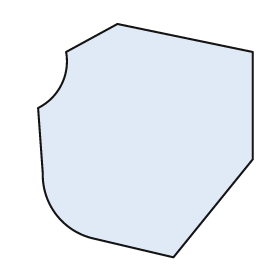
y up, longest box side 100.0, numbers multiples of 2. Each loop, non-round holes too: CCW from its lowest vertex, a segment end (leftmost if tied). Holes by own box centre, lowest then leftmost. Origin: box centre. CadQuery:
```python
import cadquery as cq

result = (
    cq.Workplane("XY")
    .moveTo(12.0, -50.0)
    .lineTo(46.0, -8.0)
    .lineTo(46.0, 38.0)
    .lineTo(-12.0, 50.0)
    .lineTo(-34.0, 38.0)
    .threePointArc((-36.0, 24.0), (-46.0, 14.0))
    .lineTo(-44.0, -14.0)
    .threePointArc((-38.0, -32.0), (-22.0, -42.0))
    .close()
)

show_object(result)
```